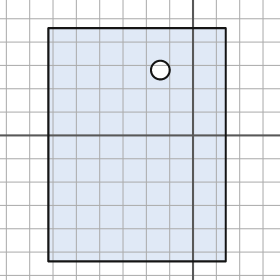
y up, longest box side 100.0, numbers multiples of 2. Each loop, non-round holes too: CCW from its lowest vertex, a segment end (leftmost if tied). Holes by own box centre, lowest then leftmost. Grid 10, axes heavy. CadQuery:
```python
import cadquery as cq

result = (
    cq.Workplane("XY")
    .moveTo(-62.0, -54.0)
    .lineTo(14.0, -54.0)
    .lineTo(14.0, 46.0)
    .lineTo(-62.0, 46.0)
    .close()
    .moveTo(-14.0, 28.0)
    .circle(4.0)
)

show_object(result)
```